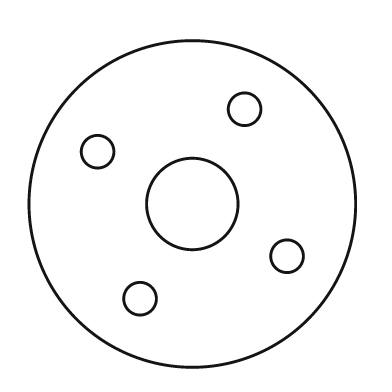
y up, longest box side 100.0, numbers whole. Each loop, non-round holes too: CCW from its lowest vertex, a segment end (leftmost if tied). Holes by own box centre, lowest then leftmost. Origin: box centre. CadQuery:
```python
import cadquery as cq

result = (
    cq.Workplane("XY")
    .moveTo(0.0, 0.0)
    .circle(50.0)
    .moveTo(-16.0, -29.0)
    .circle(5.0)
    .moveTo(29.0, -16.0)
    .circle(5.0)
    .moveTo(0.0, 0.0)
    .circle(14.0)
    .moveTo(-29.0, 16.0)
    .circle(5.0)
    .moveTo(16.0, 29.0)
    .circle(5.0)
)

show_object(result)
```